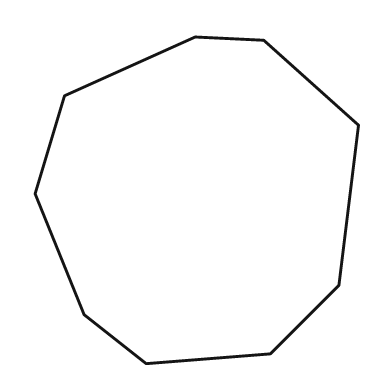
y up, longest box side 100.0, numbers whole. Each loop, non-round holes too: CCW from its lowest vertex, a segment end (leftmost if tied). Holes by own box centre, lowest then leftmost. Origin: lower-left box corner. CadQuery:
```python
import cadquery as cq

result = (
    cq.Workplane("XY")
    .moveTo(34.0, 0.0)
    .lineTo(72.0, 3.0)
    .lineTo(93.0, 24.0)
    .lineTo(99.0, 73.0)
    .lineTo(70.0, 99.0)
    .lineTo(49.0, 100.0)
    .lineTo(9.0, 82.0)
    .lineTo(0.0, 52.0)
    .lineTo(15.0, 15.0)
    .close()
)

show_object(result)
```